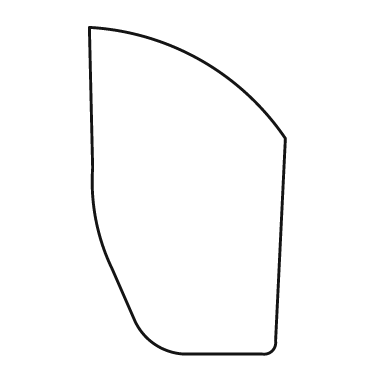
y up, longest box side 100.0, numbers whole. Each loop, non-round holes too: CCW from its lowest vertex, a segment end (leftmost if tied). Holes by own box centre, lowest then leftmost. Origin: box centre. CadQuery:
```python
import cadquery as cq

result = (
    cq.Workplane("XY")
    .moveTo(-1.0, -50.0)
    .lineTo(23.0, -50.0)
    .threePointArc((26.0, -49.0), (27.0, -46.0))
    .lineTo(30.0, 16.0)
    .threePointArc((4.0, 40.0), (-30.0, 50.0))
    .lineTo(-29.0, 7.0)
    .threePointArc((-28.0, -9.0), (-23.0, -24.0))
    .lineTo(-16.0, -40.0)
    .threePointArc((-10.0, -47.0), (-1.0, -50.0))
    .close()
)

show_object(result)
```